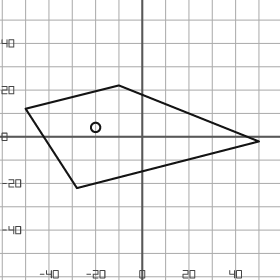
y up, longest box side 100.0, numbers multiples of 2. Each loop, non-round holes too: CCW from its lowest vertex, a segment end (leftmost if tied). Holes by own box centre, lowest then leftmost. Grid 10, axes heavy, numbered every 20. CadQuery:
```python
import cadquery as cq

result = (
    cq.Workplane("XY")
    .moveTo(-28.0, -22.0)
    .lineTo(50.0, -2.0)
    .lineTo(-10.0, 22.0)
    .lineTo(-50.0, 12.0)
    .close()
    .moveTo(-20.0, 4.0)
    .circle(2.0)
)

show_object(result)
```